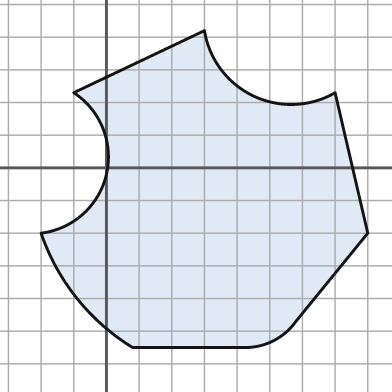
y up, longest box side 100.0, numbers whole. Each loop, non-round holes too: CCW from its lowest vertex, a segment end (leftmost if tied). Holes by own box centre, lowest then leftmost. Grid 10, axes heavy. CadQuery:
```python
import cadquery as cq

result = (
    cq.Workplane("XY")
    .moveTo(8.0, -55.0)
    .lineTo(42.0, -55.0)
    .threePointArc((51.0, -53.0), (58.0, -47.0))
    .lineTo(80.0, -20.0)
    .lineTo(70.0, 23.0)
    .threePointArc((45.0, 22.0), (30.0, 42.0))
    .lineTo(-10.0, 23.0)
    .threePointArc((0.0, -2.0), (-20.0, -20.0))
    .threePointArc((-9.0, -40.0), (8.0, -55.0))
    .close()
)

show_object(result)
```